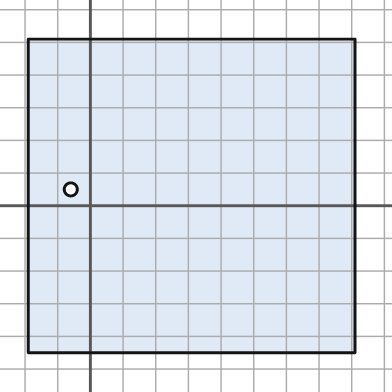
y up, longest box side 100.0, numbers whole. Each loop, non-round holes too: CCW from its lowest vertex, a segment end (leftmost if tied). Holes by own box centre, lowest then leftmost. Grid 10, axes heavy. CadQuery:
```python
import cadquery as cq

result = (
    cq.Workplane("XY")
    .moveTo(-19.0, -45.0)
    .lineTo(81.0, -45.0)
    .lineTo(81.0, 51.0)
    .lineTo(-19.0, 51.0)
    .close()
    .moveTo(-6.0, 5.0)
    .circle(2.0)
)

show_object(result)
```